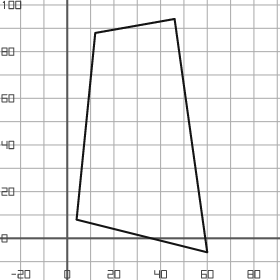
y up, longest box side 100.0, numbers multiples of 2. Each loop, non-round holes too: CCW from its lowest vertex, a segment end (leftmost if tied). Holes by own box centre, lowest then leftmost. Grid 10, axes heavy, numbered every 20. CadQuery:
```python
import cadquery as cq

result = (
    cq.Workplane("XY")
    .moveTo(60.0, -6.0)
    .lineTo(46.0, 94.0)
    .lineTo(12.0, 88.0)
    .lineTo(4.0, 8.0)
    .close()
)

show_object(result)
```